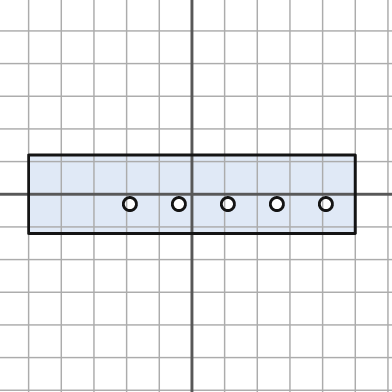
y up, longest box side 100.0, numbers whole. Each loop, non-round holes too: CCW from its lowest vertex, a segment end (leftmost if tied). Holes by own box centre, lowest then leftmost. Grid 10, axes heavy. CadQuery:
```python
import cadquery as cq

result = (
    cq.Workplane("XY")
    .moveTo(-50.0, -12.0)
    .lineTo(50.0, -12.0)
    .lineTo(50.0, 12.0)
    .lineTo(-50.0, 12.0)
    .close()
    .moveTo(-19.0, -3.0)
    .circle(2.0)
    .moveTo(-4.0, -3.0)
    .circle(2.0)
    .moveTo(11.0, -3.0)
    .circle(2.0)
    .moveTo(26.0, -3.0)
    .circle(2.0)
    .moveTo(41.0, -3.0)
    .circle(2.0)
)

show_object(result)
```